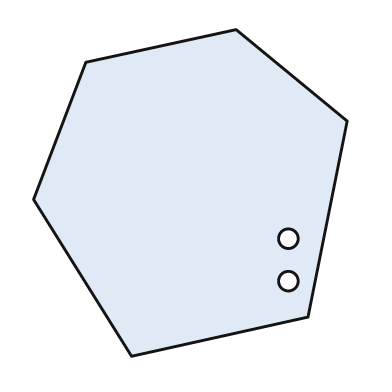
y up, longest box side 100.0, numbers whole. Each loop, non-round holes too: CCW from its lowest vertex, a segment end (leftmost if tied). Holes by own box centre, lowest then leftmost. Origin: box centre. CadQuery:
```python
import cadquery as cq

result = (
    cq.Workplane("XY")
    .moveTo(-18.0, -50.0)
    .lineTo(36.0, -38.0)
    .lineTo(48.0, 22.0)
    .lineTo(14.0, 50.0)
    .lineTo(-32.0, 40.0)
    .lineTo(-48.0, -2.0)
    .close()
    .moveTo(30.0, -27.0)
    .circle(3.0)
    .moveTo(30.0, -14.0)
    .circle(3.0)
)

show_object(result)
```